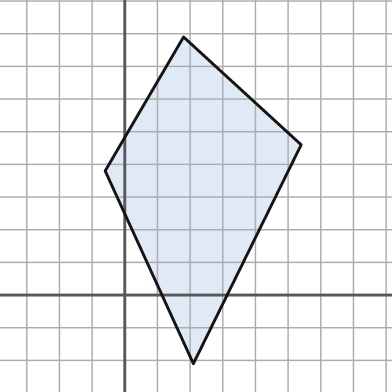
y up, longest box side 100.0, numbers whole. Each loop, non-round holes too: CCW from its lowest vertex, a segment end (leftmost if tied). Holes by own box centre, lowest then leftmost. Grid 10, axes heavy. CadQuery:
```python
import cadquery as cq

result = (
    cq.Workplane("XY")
    .moveTo(21.0, -21.0)
    .lineTo(54.0, 46.0)
    .lineTo(18.0, 79.0)
    .lineTo(-6.0, 38.0)
    .close()
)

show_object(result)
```